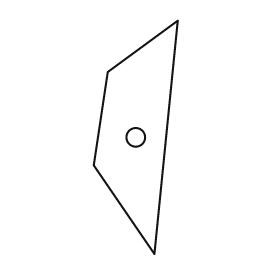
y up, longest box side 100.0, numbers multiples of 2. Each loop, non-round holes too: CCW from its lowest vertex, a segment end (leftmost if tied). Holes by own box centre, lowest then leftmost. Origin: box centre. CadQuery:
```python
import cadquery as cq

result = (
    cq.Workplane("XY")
    .moveTo(8.0, -50.0)
    .lineTo(18.0, 50.0)
    .lineTo(-12.0, 28.0)
    .lineTo(-18.0, -12.0)
    .close()
    .moveTo(0.0, 0.0)
    .circle(4.0)
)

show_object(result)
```